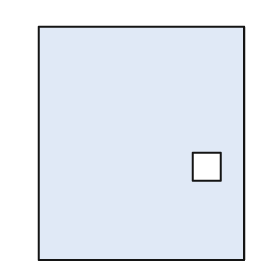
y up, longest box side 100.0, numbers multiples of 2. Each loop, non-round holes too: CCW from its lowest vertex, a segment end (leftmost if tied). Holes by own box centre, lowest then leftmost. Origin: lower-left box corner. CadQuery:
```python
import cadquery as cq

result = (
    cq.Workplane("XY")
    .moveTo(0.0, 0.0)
    .lineTo(88.0, 0.0)
    .lineTo(88.0, 100.0)
    .lineTo(0.0, 100.0)
    .close()
    .moveTo(66.0, 34.0)
    .lineTo(78.0, 34.0)
    .lineTo(78.0, 46.0)
    .lineTo(66.0, 46.0)
    .close()
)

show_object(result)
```